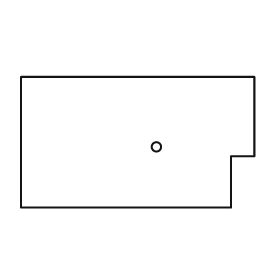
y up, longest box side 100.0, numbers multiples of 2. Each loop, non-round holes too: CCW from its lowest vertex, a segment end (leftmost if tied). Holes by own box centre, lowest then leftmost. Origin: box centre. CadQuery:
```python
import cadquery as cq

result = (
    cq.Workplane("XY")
    .moveTo(-50.0, -28.0)
    .lineTo(40.0, -28.0)
    .lineTo(40.0, -6.0)
    .lineTo(50.0, -6.0)
    .lineTo(50.0, 28.0)
    .lineTo(-50.0, 28.0)
    .close()
    .moveTo(8.0, -2.0)
    .circle(2.0)
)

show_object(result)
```